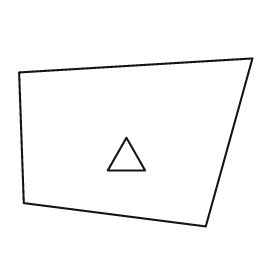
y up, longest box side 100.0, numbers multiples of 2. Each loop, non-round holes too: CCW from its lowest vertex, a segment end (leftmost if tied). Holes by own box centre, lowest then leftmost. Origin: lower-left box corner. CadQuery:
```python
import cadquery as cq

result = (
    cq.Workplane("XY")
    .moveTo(80.0, 0.0)
    .lineTo(100.0, 72.0)
    .lineTo(0.0, 66.0)
    .lineTo(2.0, 10.0)
    .close()
    .moveTo(38.0, 24.0)
    .lineTo(54.0, 24.0)
    .lineTo(46.0, 38.0)
    .close()
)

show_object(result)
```